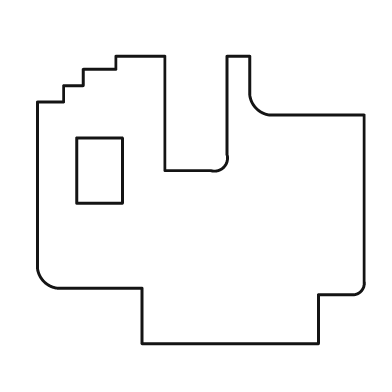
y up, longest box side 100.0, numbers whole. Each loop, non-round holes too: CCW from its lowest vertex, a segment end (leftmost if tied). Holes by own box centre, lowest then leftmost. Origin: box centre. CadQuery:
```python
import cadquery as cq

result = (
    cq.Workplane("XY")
    .moveTo(-18.0, -44.0)
    .lineTo(36.0, -44.0)
    .lineTo(36.0, -29.0)
    .lineTo(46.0, -29.0)
    .threePointArc((49.0, -28.0), (50.0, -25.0))
    .lineTo(50.0, 26.0)
    .lineTo(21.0, 26.0)
    .threePointArc((17.0, 28.0), (15.0, 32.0))
    .lineTo(15.0, 44.0)
    .lineTo(8.0, 44.0)
    .lineTo(8.0, 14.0)
    .threePointArc((7.0, 10.0), (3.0, 9.0))
    .lineTo(-11.0, 9.0)
    .lineTo(-11.0, 44.0)
    .lineTo(-26.0, 44.0)
    .lineTo(-26.0, 40.0)
    .lineTo(-36.0, 40.0)
    .lineTo(-36.0, 35.0)
    .lineTo(-42.0, 35.0)
    .lineTo(-42.0, 30.0)
    .lineTo(-50.0, 30.0)
    .lineTo(-50.0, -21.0)
    .threePointArc((-48.0, -25.0), (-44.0, -27.0))
    .lineTo(-18.0, -27.0)
    .close()
    .moveTo(-38.0, -1.0)
    .lineTo(-24.0, -1.0)
    .lineTo(-24.0, 19.0)
    .lineTo(-38.0, 19.0)
    .close()
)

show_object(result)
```